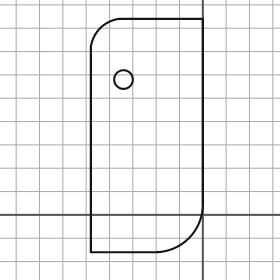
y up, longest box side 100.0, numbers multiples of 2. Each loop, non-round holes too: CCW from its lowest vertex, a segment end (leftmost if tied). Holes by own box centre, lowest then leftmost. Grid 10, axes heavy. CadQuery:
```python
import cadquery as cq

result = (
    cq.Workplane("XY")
    .moveTo(-48.0, -16.0)
    .lineTo(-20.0, -16.0)
    .threePointArc((-6.0, -10.0), (0.0, 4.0))
    .lineTo(0.0, 84.0)
    .lineTo(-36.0, 84.0)
    .threePointArc((-44.0, 80.0), (-48.0, 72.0))
    .close()
    .moveTo(-34.0, 58.0)
    .circle(4.0)
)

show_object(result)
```